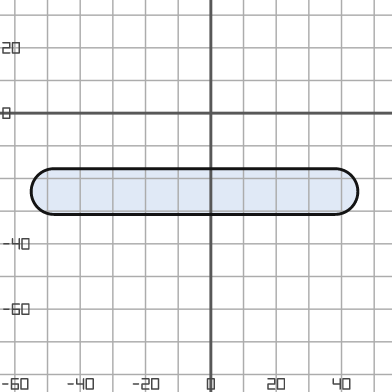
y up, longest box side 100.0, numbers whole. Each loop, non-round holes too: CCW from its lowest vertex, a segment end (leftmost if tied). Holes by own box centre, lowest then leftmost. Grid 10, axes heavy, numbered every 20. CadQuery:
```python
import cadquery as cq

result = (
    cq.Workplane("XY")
    .moveTo(-48.0, -31.0)
    .lineTo(38.0, -31.0)
    .threePointArc((45.0, -24.0), (38.0, -17.0))
    .lineTo(-48.0, -17.0)
    .threePointArc((-55.0, -24.0), (-48.0, -31.0))
    .close()
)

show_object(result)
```